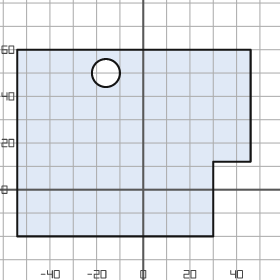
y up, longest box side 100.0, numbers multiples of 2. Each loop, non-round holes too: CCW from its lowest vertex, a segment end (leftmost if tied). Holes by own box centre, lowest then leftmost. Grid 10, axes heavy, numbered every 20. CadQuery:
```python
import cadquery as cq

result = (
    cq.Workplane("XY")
    .moveTo(-54.0, -20.0)
    .lineTo(30.0, -20.0)
    .lineTo(30.0, 12.0)
    .lineTo(46.0, 12.0)
    .lineTo(46.0, 60.0)
    .lineTo(-54.0, 60.0)
    .close()
    .moveTo(-16.0, 50.0)
    .circle(6.0)
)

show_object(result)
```